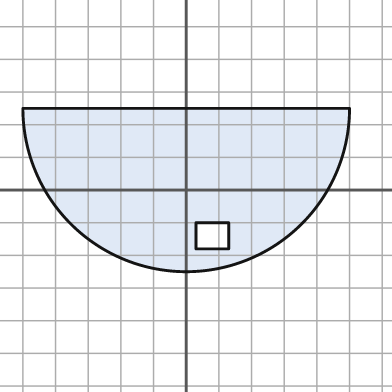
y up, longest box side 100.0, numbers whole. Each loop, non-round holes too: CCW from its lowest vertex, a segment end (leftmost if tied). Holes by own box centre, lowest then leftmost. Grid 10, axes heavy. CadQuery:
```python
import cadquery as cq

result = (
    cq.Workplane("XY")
    .moveTo(-50.0, 25.0)
    .threePointArc((0.0, -25.0), (50.0, 25.0))
    .close()
    .moveTo(3.0, -18.0)
    .lineTo(13.0, -18.0)
    .lineTo(13.0, -10.0)
    .lineTo(3.0, -10.0)
    .close()
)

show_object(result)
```